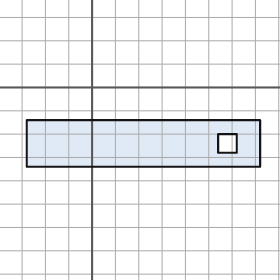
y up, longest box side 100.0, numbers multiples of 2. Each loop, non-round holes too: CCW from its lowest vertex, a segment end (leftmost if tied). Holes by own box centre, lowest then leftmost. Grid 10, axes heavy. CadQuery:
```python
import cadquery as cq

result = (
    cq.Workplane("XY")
    .moveTo(-28.0, -34.0)
    .lineTo(72.0, -34.0)
    .lineTo(72.0, -14.0)
    .lineTo(-28.0, -14.0)
    .close()
    .moveTo(54.0, -28.0)
    .lineTo(62.0, -28.0)
    .lineTo(62.0, -20.0)
    .lineTo(54.0, -20.0)
    .close()
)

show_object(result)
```